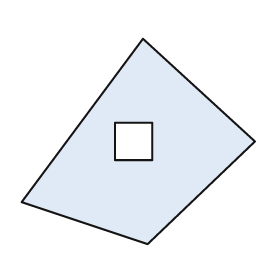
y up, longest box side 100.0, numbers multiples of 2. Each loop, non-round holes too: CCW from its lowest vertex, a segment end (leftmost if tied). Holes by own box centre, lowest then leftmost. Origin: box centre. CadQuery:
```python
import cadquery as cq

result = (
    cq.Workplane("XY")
    .moveTo(4.0, -44.0)
    .lineTo(50.0, 0.0)
    .lineTo(2.0, 44.0)
    .lineTo(-50.0, -26.0)
    .close()
    .moveTo(-10.0, -8.0)
    .lineTo(6.0, -8.0)
    .lineTo(6.0, 8.0)
    .lineTo(-10.0, 8.0)
    .close()
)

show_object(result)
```